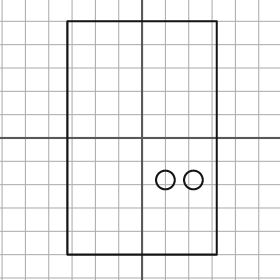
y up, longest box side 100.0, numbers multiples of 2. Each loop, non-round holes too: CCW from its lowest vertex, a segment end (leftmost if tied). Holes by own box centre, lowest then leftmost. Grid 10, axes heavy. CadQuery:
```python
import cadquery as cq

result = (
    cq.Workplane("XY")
    .moveTo(-32.0, -50.0)
    .lineTo(32.0, -50.0)
    .lineTo(32.0, 50.0)
    .lineTo(-32.0, 50.0)
    .close()
    .moveTo(10.0, -18.0)
    .circle(4.0)
    .moveTo(22.0, -18.0)
    .circle(4.0)
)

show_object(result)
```